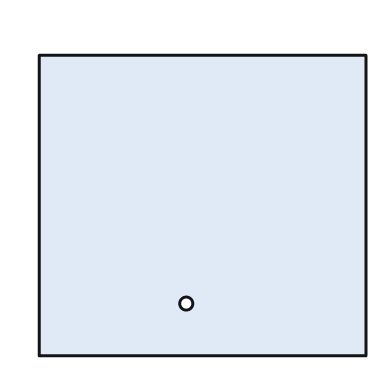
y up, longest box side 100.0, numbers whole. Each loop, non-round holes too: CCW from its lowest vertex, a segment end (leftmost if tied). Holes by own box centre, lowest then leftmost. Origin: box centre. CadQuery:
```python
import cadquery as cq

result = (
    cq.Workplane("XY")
    .moveTo(-50.0, -46.0)
    .lineTo(50.0, -46.0)
    .lineTo(50.0, 46.0)
    .lineTo(-50.0, 46.0)
    .close()
    .moveTo(-5.0, -30.0)
    .circle(2.0)
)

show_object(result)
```